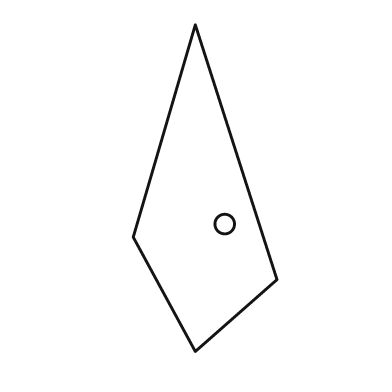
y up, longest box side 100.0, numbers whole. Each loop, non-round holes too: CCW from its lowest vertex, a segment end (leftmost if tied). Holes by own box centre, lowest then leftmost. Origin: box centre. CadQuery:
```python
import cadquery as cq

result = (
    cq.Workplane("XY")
    .moveTo(-3.0, -50.0)
    .lineTo(22.0, -28.0)
    .lineTo(-3.0, 50.0)
    .lineTo(-22.0, -15.0)
    .close()
    .moveTo(6.0, -11.0)
    .circle(3.0)
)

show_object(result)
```